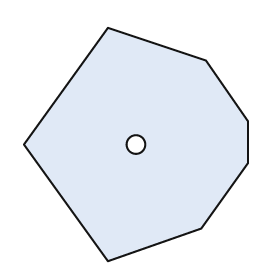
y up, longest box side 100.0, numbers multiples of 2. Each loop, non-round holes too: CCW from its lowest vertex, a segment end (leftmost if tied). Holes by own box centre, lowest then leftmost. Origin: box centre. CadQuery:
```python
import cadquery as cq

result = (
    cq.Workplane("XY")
    .moveTo(-12.0, -50.0)
    .lineTo(28.0, -36.0)
    .lineTo(48.0, -8.0)
    .lineTo(48.0, 10.0)
    .lineTo(30.0, 36.0)
    .lineTo(-12.0, 50.0)
    .lineTo(-48.0, 0.0)
    .close()
    .moveTo(0.0, 0.0)
    .circle(4.0)
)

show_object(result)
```